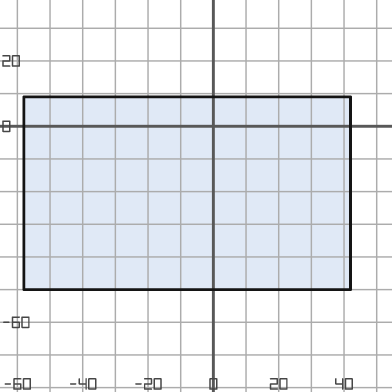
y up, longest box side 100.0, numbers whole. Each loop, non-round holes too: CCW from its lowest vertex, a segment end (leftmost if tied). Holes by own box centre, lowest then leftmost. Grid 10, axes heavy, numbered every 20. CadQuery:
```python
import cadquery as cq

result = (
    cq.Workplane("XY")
    .moveTo(-58.0, -50.0)
    .lineTo(42.0, -50.0)
    .lineTo(42.0, 9.0)
    .lineTo(-58.0, 9.0)
    .close()
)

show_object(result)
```